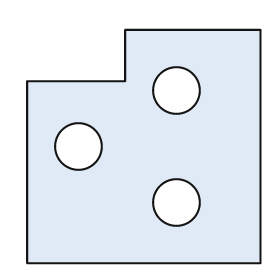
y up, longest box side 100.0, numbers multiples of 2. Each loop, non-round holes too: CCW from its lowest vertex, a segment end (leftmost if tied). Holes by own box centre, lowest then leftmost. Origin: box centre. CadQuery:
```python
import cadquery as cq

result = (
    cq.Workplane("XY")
    .moveTo(-50.0, -50.0)
    .lineTo(50.0, -50.0)
    .lineTo(50.0, 50.0)
    .lineTo(-8.0, 50.0)
    .lineTo(-8.0, 28.0)
    .lineTo(-50.0, 28.0)
    .close()
    .moveTo(14.0, -24.0)
    .circle(10.0)
    .moveTo(-28.0, 0.0)
    .circle(10.0)
    .moveTo(14.0, 24.0)
    .circle(10.0)
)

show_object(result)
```